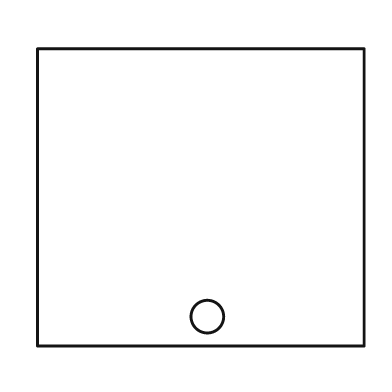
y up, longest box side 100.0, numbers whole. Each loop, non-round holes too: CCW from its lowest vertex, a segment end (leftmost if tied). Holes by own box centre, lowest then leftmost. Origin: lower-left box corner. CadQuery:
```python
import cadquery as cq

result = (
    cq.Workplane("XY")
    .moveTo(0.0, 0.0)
    .lineTo(100.0, 0.0)
    .lineTo(100.0, 91.0)
    .lineTo(0.0, 91.0)
    .close()
    .moveTo(52.0, 9.0)
    .circle(5.0)
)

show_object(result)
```